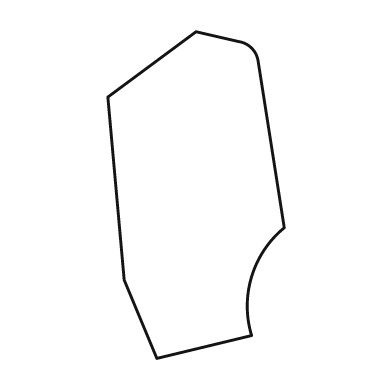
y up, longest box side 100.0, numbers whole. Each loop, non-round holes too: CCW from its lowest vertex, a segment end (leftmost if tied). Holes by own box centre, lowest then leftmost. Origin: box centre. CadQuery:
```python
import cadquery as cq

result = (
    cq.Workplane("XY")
    .moveTo(-12.0, -50.0)
    .lineTo(17.0, -43.0)
    .threePointArc((17.0, -25.0), (27.0, -10.0))
    .lineTo(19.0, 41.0)
    .threePointArc((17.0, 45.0), (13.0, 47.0))
    .lineTo(0.0, 50.0)
    .lineTo(-27.0, 30.0)
    .lineTo(-22.0, -26.0)
    .close()
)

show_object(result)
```